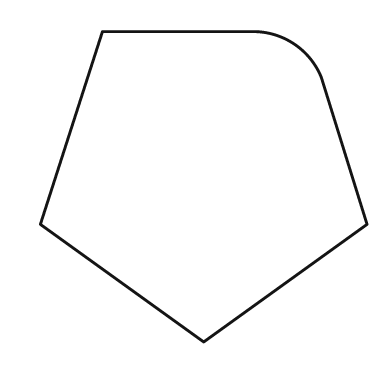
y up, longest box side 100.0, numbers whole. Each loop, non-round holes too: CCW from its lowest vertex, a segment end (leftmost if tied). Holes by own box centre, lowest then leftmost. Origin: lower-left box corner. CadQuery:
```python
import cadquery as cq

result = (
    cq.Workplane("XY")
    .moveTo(50.0, 0.0)
    .lineTo(100.0, 36.0)
    .lineTo(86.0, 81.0)
    .threePointArc((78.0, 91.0), (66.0, 95.0))
    .lineTo(19.0, 95.0)
    .lineTo(0.0, 36.0)
    .close()
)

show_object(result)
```